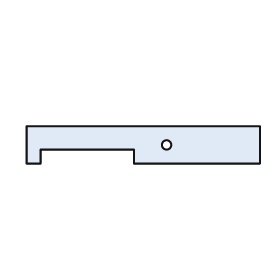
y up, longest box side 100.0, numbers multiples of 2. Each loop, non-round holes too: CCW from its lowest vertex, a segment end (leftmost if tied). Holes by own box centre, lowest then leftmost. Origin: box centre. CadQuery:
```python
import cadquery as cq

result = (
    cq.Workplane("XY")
    .moveTo(-50.0, -8.0)
    .lineTo(-44.0, -8.0)
    .lineTo(-44.0, -2.0)
    .lineTo(-4.0, -2.0)
    .lineTo(-4.0, -8.0)
    .lineTo(50.0, -8.0)
    .lineTo(50.0, 8.0)
    .lineTo(-50.0, 8.0)
    .close()
    .moveTo(10.0, 0.0)
    .circle(2.0)
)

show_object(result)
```